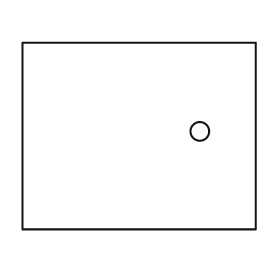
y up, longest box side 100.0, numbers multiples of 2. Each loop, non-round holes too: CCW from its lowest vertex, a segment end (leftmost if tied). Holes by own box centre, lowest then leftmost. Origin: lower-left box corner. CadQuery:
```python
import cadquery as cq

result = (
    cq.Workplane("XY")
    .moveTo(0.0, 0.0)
    .lineTo(100.0, 0.0)
    .lineTo(100.0, 80.0)
    .lineTo(0.0, 80.0)
    .close()
    .moveTo(76.0, 42.0)
    .circle(4.0)
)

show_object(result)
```